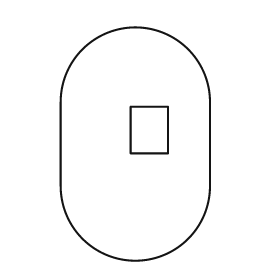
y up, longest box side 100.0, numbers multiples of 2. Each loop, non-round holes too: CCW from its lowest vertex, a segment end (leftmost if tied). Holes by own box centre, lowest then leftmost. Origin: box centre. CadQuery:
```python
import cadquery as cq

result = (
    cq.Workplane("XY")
    .moveTo(-32.0, -18.0)
    .threePointArc((0.0, -50.0), (32.0, -18.0))
    .lineTo(32.0, 18.0)
    .threePointArc((0.0, 50.0), (-32.0, 18.0))
    .close()
    .moveTo(-2.0, -4.0)
    .lineTo(14.0, -4.0)
    .lineTo(14.0, 16.0)
    .lineTo(-2.0, 16.0)
    .close()
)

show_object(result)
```